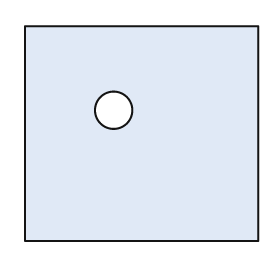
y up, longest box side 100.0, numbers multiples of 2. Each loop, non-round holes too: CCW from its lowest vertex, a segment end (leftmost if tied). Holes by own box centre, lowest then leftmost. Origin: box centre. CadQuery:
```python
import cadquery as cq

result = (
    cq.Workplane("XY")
    .moveTo(-50.0, -46.0)
    .lineTo(50.0, -46.0)
    .lineTo(50.0, 46.0)
    .lineTo(-50.0, 46.0)
    .close()
    .moveTo(-12.0, 10.0)
    .circle(8.0)
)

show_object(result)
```